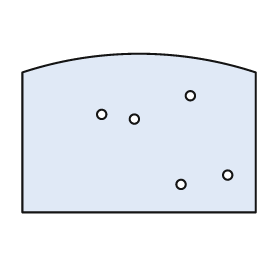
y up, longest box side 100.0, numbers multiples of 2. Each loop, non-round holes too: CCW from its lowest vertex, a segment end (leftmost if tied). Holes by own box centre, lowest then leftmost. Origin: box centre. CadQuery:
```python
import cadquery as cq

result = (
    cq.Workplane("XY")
    .moveTo(-50.0, -34.0)
    .lineTo(50.0, -34.0)
    .lineTo(50.0, 26.0)
    .threePointArc((0.0, 34.0), (-50.0, 26.0))
    .close()
    .moveTo(18.0, -22.0)
    .circle(2.0)
    .moveTo(38.0, -18.0)
    .circle(2.0)
    .moveTo(-2.0, 6.0)
    .circle(2.0)
    .moveTo(-16.0, 8.0)
    .circle(2.0)
    .moveTo(22.0, 16.0)
    .circle(2.0)
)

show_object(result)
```